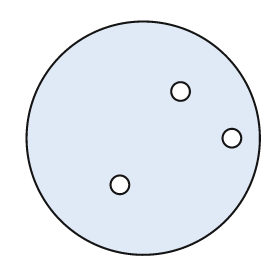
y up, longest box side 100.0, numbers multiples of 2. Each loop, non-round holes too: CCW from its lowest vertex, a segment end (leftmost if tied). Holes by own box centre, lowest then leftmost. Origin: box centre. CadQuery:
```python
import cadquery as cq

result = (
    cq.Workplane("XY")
    .moveTo(0.0, 0.0)
    .circle(50.0)
    .moveTo(-10.0, -20.0)
    .circle(4.0)
    .moveTo(38.0, 0.0)
    .circle(4.0)
    .moveTo(16.0, 20.0)
    .circle(4.0)
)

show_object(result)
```